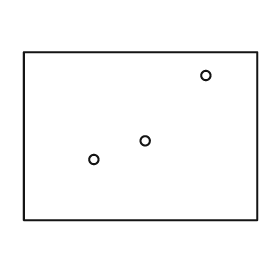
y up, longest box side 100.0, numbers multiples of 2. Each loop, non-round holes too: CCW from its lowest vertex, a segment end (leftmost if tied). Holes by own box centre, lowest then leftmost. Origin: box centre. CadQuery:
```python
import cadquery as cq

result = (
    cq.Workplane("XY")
    .moveTo(-50.0, -36.0)
    .lineTo(50.0, -36.0)
    .lineTo(50.0, 36.0)
    .lineTo(-50.0, 36.0)
    .close()
    .moveTo(-20.0, -10.0)
    .circle(2.0)
    .moveTo(2.0, -2.0)
    .circle(2.0)
    .moveTo(28.0, 26.0)
    .circle(2.0)
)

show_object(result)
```